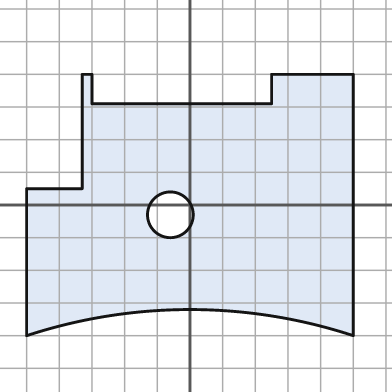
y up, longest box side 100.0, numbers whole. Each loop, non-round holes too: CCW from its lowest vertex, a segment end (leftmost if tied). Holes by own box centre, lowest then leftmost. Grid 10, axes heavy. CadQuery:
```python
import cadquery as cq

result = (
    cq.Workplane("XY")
    .moveTo(-50.0, -40.0)
    .threePointArc((0.0, -32.0), (50.0, -40.0))
    .lineTo(50.0, 40.0)
    .lineTo(25.0, 40.0)
    .lineTo(25.0, 31.0)
    .lineTo(-30.0, 31.0)
    .lineTo(-30.0, 40.0)
    .lineTo(-33.0, 40.0)
    .lineTo(-33.0, 5.0)
    .lineTo(-50.0, 5.0)
    .close()
    .moveTo(-6.0, -3.0)
    .circle(7.0)
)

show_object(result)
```